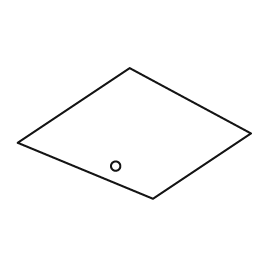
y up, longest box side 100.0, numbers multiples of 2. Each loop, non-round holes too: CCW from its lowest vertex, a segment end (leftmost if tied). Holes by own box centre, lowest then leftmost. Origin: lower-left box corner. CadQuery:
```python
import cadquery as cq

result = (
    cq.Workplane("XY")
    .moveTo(58.0, 0.0)
    .lineTo(100.0, 28.0)
    .lineTo(48.0, 56.0)
    .lineTo(0.0, 24.0)
    .close()
    .moveTo(42.0, 14.0)
    .circle(2.0)
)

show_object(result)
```